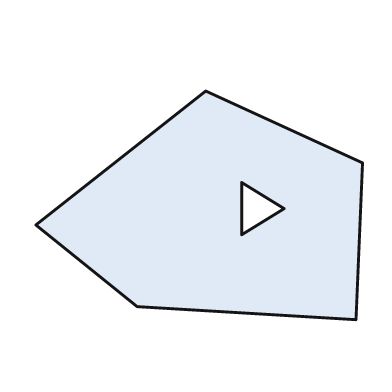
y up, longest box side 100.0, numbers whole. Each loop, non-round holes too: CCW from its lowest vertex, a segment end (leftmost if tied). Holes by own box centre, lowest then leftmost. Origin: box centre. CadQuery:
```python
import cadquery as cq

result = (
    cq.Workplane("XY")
    .moveTo(48.0, -35.0)
    .lineTo(50.0, 13.0)
    .lineTo(2.0, 35.0)
    .lineTo(-50.0, -6.0)
    .lineTo(-19.0, -31.0)
    .close()
    .moveTo(13.0, -9.0)
    .lineTo(26.0, -1.0)
    .lineTo(13.0, 7.0)
    .close()
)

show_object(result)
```